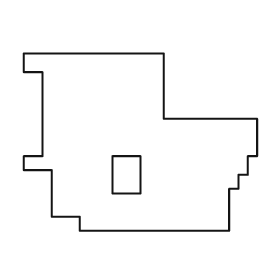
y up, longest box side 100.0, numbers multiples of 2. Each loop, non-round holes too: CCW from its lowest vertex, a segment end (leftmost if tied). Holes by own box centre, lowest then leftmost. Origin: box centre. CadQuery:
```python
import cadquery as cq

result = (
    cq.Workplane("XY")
    .moveTo(-26.0, -38.0)
    .lineTo(38.0, -38.0)
    .lineTo(38.0, -20.0)
    .lineTo(42.0, -20.0)
    .lineTo(42.0, -14.0)
    .lineTo(46.0, -14.0)
    .lineTo(46.0, -6.0)
    .lineTo(50.0, -6.0)
    .lineTo(50.0, 10.0)
    .lineTo(10.0, 10.0)
    .lineTo(10.0, 38.0)
    .lineTo(-50.0, 38.0)
    .lineTo(-50.0, 30.0)
    .lineTo(-42.0, 30.0)
    .lineTo(-42.0, -6.0)
    .lineTo(-50.0, -6.0)
    .lineTo(-50.0, -12.0)
    .lineTo(-38.0, -12.0)
    .lineTo(-38.0, -32.0)
    .lineTo(-26.0, -32.0)
    .close()
    .moveTo(-12.0, -22.0)
    .lineTo(0.0, -22.0)
    .lineTo(0.0, -6.0)
    .lineTo(-12.0, -6.0)
    .close()
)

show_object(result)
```